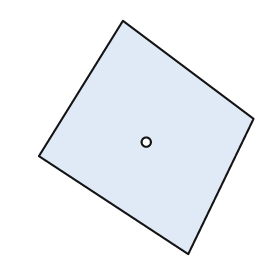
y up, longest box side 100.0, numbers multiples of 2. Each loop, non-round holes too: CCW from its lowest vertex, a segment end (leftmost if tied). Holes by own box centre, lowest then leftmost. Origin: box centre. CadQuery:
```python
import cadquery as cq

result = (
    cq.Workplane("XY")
    .moveTo(18.0, -50.0)
    .lineTo(46.0, 8.0)
    .lineTo(-10.0, 50.0)
    .lineTo(-46.0, -8.0)
    .close()
    .moveTo(0.0, -2.0)
    .circle(2.0)
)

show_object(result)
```